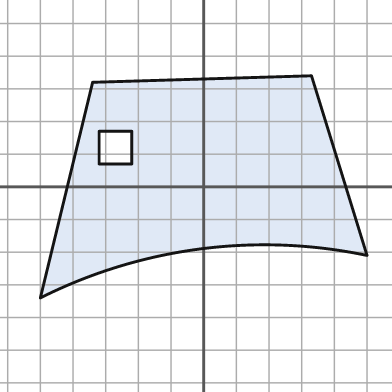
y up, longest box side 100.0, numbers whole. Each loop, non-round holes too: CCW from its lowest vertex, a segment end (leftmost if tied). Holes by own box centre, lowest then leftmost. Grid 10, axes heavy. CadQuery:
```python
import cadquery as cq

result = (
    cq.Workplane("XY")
    .moveTo(-50.0, -34.0)
    .threePointArc((-1.0, -19.0), (50.0, -21.0))
    .lineTo(33.0, 34.0)
    .lineTo(-34.0, 32.0)
    .close()
    .moveTo(-32.0, 7.0)
    .lineTo(-22.0, 7.0)
    .lineTo(-22.0, 17.0)
    .lineTo(-32.0, 17.0)
    .close()
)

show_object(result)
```